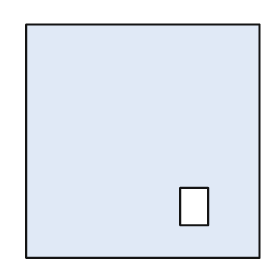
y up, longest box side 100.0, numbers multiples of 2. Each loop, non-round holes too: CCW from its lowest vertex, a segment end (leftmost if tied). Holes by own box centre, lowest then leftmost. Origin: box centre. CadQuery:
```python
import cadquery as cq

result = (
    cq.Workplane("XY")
    .moveTo(-50.0, -50.0)
    .lineTo(50.0, -50.0)
    .lineTo(50.0, 50.0)
    .lineTo(-50.0, 50.0)
    .close()
    .moveTo(16.0, -36.0)
    .lineTo(28.0, -36.0)
    .lineTo(28.0, -20.0)
    .lineTo(16.0, -20.0)
    .close()
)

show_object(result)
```